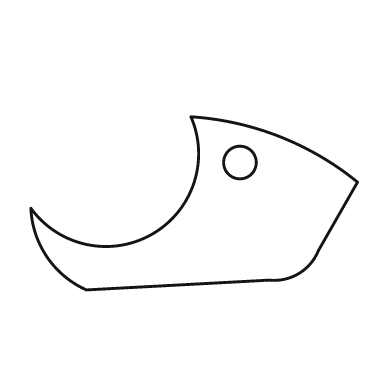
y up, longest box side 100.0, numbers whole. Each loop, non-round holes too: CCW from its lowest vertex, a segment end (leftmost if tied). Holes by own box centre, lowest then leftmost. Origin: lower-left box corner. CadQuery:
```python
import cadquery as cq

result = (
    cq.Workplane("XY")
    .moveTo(17.0, 0.0)
    .lineTo(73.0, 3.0)
    .threePointArc((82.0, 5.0), (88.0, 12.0))
    .lineTo(100.0, 33.0)
    .threePointArc((76.0, 47.0), (49.0, 53.0))
    .threePointArc((37.0, 17.0), (0.0, 25.0))
    .threePointArc((5.0, 10.0), (17.0, 0.0))
    .close()
    .moveTo(64.0, 39.0)
    .circle(5.0)
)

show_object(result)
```